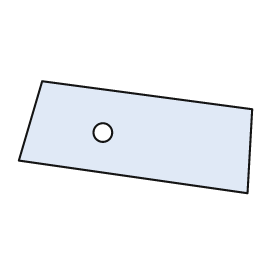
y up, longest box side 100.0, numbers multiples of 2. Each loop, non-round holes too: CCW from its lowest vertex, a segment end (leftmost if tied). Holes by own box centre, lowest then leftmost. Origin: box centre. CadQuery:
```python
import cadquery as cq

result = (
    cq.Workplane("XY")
    .moveTo(48.0, -24.0)
    .lineTo(50.0, 12.0)
    .lineTo(-40.0, 24.0)
    .lineTo(-50.0, -10.0)
    .close()
    .moveTo(-14.0, 2.0)
    .circle(4.0)
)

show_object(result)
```